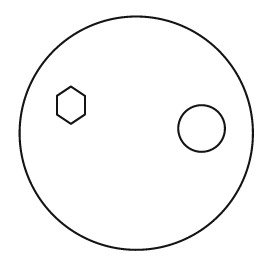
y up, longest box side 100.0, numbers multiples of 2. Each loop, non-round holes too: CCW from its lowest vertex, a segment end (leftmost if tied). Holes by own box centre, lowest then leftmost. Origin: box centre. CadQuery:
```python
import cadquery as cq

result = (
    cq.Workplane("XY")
    .moveTo(0.0, 0.0)
    .circle(50.0)
    .moveTo(28.0, 2.0)
    .circle(10.0)
    .moveTo(-28.0, 4.0)
    .lineTo(-22.0, 8.0)
    .lineTo(-22.0, 16.0)
    .lineTo(-28.0, 20.0)
    .lineTo(-34.0, 16.0)
    .lineTo(-34.0, 8.0)
    .close()
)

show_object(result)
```